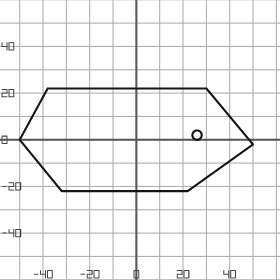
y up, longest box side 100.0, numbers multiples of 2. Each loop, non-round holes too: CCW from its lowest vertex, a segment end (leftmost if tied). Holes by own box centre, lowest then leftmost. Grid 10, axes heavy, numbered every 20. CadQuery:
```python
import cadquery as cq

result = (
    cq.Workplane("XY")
    .moveTo(-32.0, -22.0)
    .lineTo(22.0, -22.0)
    .lineTo(50.0, -2.0)
    .lineTo(30.0, 22.0)
    .lineTo(-38.0, 22.0)
    .lineTo(-50.0, 0.0)
    .close()
    .moveTo(26.0, 2.0)
    .circle(2.0)
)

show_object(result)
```